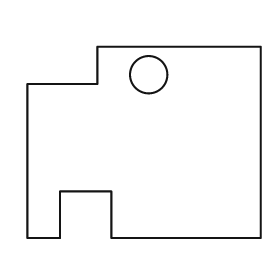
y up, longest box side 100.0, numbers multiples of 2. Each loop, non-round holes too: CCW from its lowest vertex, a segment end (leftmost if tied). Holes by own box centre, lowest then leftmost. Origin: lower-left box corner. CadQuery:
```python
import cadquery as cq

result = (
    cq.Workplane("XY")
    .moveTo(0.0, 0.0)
    .lineTo(14.0, 0.0)
    .lineTo(14.0, 20.0)
    .lineTo(36.0, 20.0)
    .lineTo(36.0, 0.0)
    .lineTo(100.0, 0.0)
    .lineTo(100.0, 82.0)
    .lineTo(30.0, 82.0)
    .lineTo(30.0, 66.0)
    .lineTo(0.0, 66.0)
    .close()
    .moveTo(52.0, 70.0)
    .circle(8.0)
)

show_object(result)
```